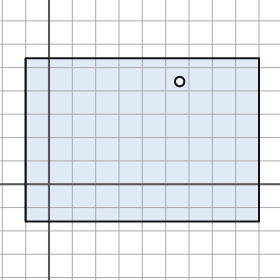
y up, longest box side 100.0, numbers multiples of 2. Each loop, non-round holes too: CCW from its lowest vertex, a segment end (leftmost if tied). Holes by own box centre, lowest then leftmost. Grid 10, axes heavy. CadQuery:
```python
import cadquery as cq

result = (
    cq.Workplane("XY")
    .moveTo(-10.0, -16.0)
    .lineTo(90.0, -16.0)
    .lineTo(90.0, 54.0)
    .lineTo(-10.0, 54.0)
    .close()
    .moveTo(56.0, 44.0)
    .circle(2.0)
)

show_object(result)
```